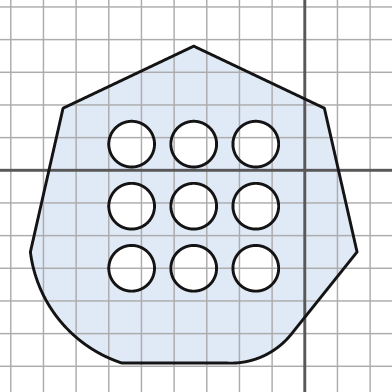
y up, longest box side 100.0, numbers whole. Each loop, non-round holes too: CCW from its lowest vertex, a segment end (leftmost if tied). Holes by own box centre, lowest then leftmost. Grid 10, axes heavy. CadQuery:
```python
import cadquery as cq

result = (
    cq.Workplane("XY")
    .moveTo(-56.0, -59.0)
    .lineTo(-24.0, -59.0)
    .threePointArc((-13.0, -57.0), (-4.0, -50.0))
    .lineTo(16.0, -25.0)
    .lineTo(6.0, 19.0)
    .lineTo(-34.0, 38.0)
    .lineTo(-74.0, 19.0)
    .lineTo(-84.0, -25.0)
    .threePointArc((-75.0, -46.0), (-56.0, -59.0))
    .close()
    .moveTo(-53.0, -30.0)
    .circle(7.0)
    .moveTo(-34.0, -30.0)
    .circle(7.0)
    .moveTo(-15.0, -30.0)
    .circle(7.0)
    .moveTo(-53.0, -11.0)
    .circle(7.0)
    .moveTo(-34.0, -11.0)
    .circle(7.0)
    .moveTo(-15.0, -11.0)
    .circle(7.0)
    .moveTo(-53.0, 8.0)
    .circle(7.0)
    .moveTo(-34.0, 8.0)
    .circle(7.0)
    .moveTo(-15.0, 8.0)
    .circle(7.0)
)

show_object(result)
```